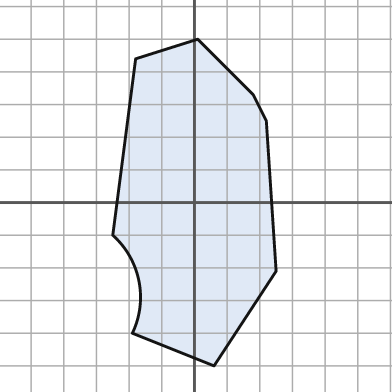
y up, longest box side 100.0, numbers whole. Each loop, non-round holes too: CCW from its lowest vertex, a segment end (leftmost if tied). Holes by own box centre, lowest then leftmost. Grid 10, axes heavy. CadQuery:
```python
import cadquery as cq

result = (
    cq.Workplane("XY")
    .moveTo(6.0, -50.0)
    .lineTo(25.0, -21.0)
    .lineTo(22.0, 25.0)
    .lineTo(18.0, 33.0)
    .lineTo(1.0, 50.0)
    .lineTo(-18.0, 44.0)
    .lineTo(-25.0, -10.0)
    .threePointArc((-17.0, -24.0), (-19.0, -40.0))
    .close()
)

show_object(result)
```